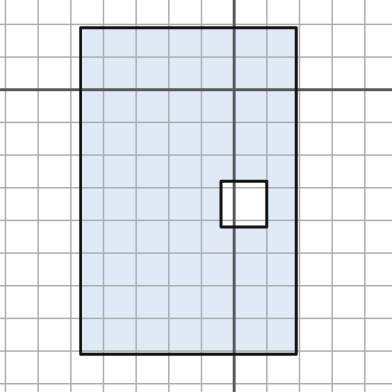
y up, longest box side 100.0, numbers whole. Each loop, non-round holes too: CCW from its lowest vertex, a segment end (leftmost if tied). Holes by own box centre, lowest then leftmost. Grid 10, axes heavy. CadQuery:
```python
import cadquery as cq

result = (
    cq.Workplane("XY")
    .moveTo(-47.0, -81.0)
    .lineTo(19.0, -81.0)
    .lineTo(19.0, 19.0)
    .lineTo(-47.0, 19.0)
    .close()
    .moveTo(-4.0, -42.0)
    .lineTo(10.0, -42.0)
    .lineTo(10.0, -28.0)
    .lineTo(-4.0, -28.0)
    .close()
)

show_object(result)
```